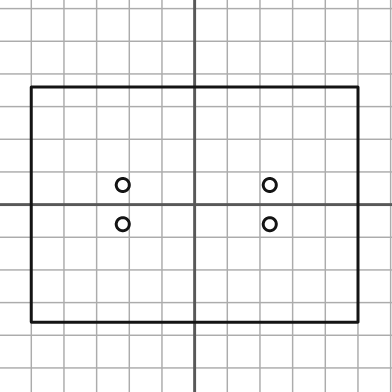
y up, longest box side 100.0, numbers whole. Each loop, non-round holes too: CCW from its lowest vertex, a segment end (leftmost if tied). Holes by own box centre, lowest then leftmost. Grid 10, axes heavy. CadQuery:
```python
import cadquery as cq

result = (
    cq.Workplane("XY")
    .moveTo(-50.0, -36.0)
    .lineTo(50.0, -36.0)
    .lineTo(50.0, 36.0)
    .lineTo(-50.0, 36.0)
    .close()
    .moveTo(-22.0, -6.0)
    .circle(2.0)
    .moveTo(23.0, -6.0)
    .circle(2.0)
    .moveTo(-22.0, 6.0)
    .circle(2.0)
    .moveTo(23.0, 6.0)
    .circle(2.0)
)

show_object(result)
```